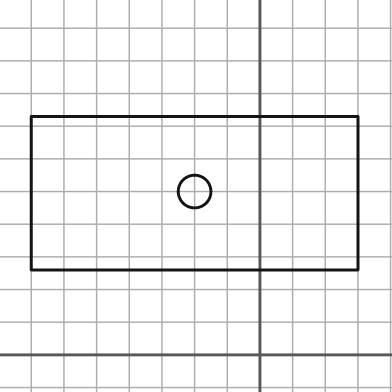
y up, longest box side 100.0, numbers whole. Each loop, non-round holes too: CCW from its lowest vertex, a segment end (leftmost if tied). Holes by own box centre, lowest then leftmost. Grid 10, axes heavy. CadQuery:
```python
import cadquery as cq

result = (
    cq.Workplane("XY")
    .moveTo(-70.0, 26.0)
    .lineTo(30.0, 26.0)
    .lineTo(30.0, 73.0)
    .lineTo(-70.0, 73.0)
    .close()
    .moveTo(-20.0, 50.0)
    .circle(5.0)
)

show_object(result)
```